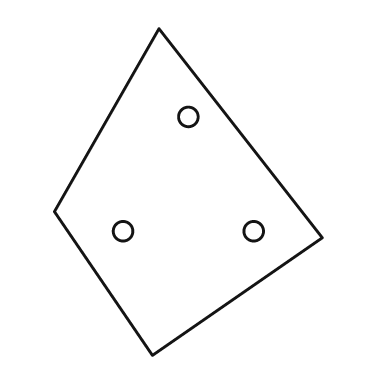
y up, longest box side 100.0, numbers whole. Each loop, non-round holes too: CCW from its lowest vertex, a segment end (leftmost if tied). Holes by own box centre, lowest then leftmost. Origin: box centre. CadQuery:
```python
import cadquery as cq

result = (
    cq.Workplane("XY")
    .moveTo(-11.0, -50.0)
    .lineTo(41.0, -14.0)
    .lineTo(-9.0, 50.0)
    .lineTo(-41.0, -6.0)
    .close()
    .moveTo(-20.0, -12.0)
    .circle(3.0)
    .moveTo(20.0, -12.0)
    .circle(3.0)
    .moveTo(0.0, 23.0)
    .circle(3.0)
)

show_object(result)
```